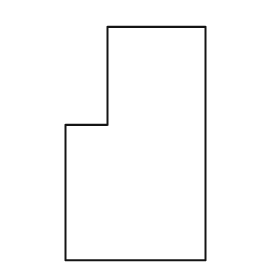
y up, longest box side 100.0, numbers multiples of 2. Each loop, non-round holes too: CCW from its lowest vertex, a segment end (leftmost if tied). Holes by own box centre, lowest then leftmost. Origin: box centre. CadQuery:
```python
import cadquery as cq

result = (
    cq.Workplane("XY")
    .moveTo(-30.0, -50.0)
    .lineTo(30.0, -50.0)
    .lineTo(30.0, 50.0)
    .lineTo(-12.0, 50.0)
    .lineTo(-12.0, 8.0)
    .lineTo(-30.0, 8.0)
    .close()
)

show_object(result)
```